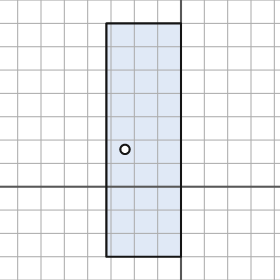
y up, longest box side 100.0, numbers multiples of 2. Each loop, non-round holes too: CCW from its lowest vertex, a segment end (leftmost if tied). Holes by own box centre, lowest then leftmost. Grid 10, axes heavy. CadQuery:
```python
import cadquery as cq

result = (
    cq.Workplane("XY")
    .moveTo(-32.0, -30.0)
    .lineTo(0.0, -30.0)
    .lineTo(0.0, 70.0)
    .lineTo(-32.0, 70.0)
    .close()
    .moveTo(-24.0, 16.0)
    .circle(2.0)
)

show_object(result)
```